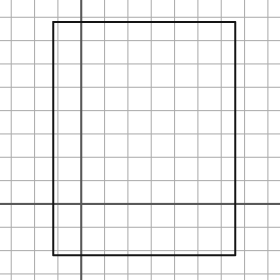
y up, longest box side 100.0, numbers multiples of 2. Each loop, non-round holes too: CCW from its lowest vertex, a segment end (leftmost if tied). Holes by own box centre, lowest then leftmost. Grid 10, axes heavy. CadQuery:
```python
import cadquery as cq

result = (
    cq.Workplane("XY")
    .moveTo(-12.0, -22.0)
    .lineTo(66.0, -22.0)
    .lineTo(66.0, 78.0)
    .lineTo(-12.0, 78.0)
    .close()
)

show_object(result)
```